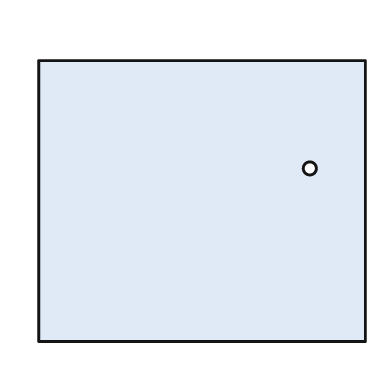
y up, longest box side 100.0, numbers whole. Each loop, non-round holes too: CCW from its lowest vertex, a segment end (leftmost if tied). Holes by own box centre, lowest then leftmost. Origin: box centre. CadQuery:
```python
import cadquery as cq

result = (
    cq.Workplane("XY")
    .moveTo(-50.0, -43.0)
    .lineTo(50.0, -43.0)
    .lineTo(50.0, 43.0)
    .lineTo(-50.0, 43.0)
    .close()
    .moveTo(33.0, 10.0)
    .circle(2.0)
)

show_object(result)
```